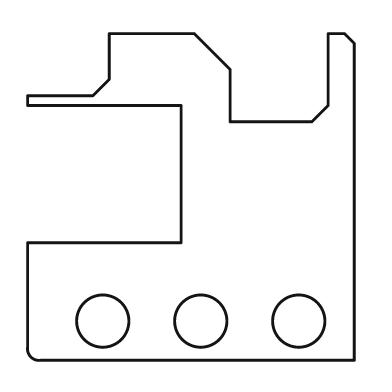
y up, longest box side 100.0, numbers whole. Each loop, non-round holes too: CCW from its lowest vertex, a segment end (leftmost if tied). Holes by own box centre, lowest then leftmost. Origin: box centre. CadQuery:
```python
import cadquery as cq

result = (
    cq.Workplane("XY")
    .moveTo(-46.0, -50.0)
    .lineTo(50.0, -50.0)
    .lineTo(50.0, 47.0)
    .lineTo(47.0, 50.0)
    .lineTo(42.0, 50.0)
    .lineTo(42.0, 28.0)
    .lineTo(37.0, 23.0)
    .lineTo(12.0, 23.0)
    .lineTo(12.0, 39.0)
    .lineTo(1.0, 50.0)
    .lineTo(-25.0, 50.0)
    .lineTo(-25.0, 36.0)
    .lineTo(-30.0, 31.0)
    .lineTo(-50.0, 31.0)
    .lineTo(-50.0, 28.0)
    .lineTo(-3.0, 28.0)
    .lineTo(-3.0, -14.0)
    .lineTo(-50.0, -14.0)
    .lineTo(-50.0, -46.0)
    .threePointArc((-49.0, -49.0), (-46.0, -50.0))
    .close()
    .moveTo(-27.0, -38.0)
    .circle(8.0)
    .moveTo(3.0, -38.0)
    .circle(8.0)
    .moveTo(33.0, -38.0)
    .circle(8.0)
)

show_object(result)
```